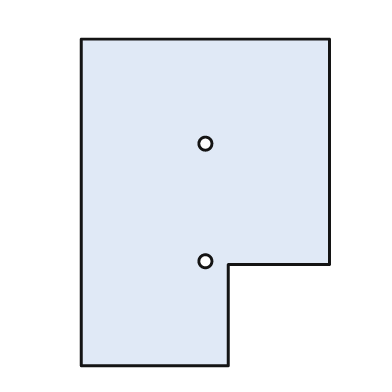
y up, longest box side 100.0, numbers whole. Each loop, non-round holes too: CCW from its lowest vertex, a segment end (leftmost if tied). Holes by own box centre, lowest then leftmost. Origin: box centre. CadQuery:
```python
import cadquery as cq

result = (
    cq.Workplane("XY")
    .moveTo(-38.0, -50.0)
    .lineTo(7.0, -50.0)
    .lineTo(7.0, -19.0)
    .lineTo(38.0, -19.0)
    .lineTo(38.0, 50.0)
    .lineTo(-38.0, 50.0)
    .close()
    .moveTo(0.0, -18.0)
    .circle(2.0)
    .moveTo(0.0, 18.0)
    .circle(2.0)
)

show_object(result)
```